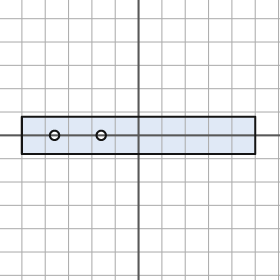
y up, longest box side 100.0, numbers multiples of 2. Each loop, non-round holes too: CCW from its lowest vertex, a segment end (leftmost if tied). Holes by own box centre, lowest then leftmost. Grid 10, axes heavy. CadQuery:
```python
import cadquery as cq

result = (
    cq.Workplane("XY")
    .moveTo(-50.0, -8.0)
    .lineTo(50.0, -8.0)
    .lineTo(50.0, 8.0)
    .lineTo(-50.0, 8.0)
    .close()
    .moveTo(-36.0, 0.0)
    .circle(2.0)
    .moveTo(-16.0, 0.0)
    .circle(2.0)
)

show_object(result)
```